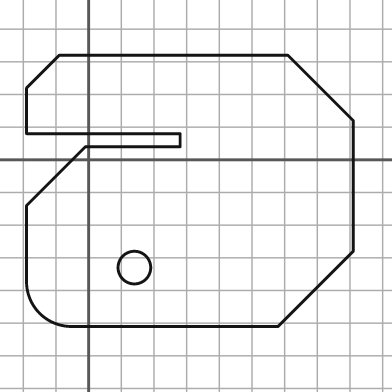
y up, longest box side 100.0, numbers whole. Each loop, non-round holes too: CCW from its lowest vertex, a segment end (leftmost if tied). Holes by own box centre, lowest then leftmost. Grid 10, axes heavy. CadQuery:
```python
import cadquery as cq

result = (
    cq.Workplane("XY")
    .moveTo(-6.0, -51.0)
    .lineTo(58.0, -51.0)
    .lineTo(81.0, -28.0)
    .lineTo(81.0, 12.0)
    .lineTo(61.0, 32.0)
    .lineTo(-9.0, 32.0)
    .lineTo(-19.0, 22.0)
    .lineTo(-19.0, 8.0)
    .lineTo(28.0, 8.0)
    .lineTo(28.0, 4.0)
    .lineTo(-1.0, 4.0)
    .lineTo(-19.0, -14.0)
    .lineTo(-19.0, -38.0)
    .threePointArc((-15.0, -47.0), (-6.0, -51.0))
    .close()
    .moveTo(14.0, -33.0)
    .circle(5.0)
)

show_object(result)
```